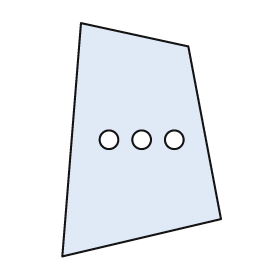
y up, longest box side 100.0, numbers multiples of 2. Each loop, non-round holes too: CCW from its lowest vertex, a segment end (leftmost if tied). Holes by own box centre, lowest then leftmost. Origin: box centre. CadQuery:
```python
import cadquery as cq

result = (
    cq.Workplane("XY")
    .moveTo(-34.0, -50.0)
    .lineTo(34.0, -34.0)
    .lineTo(20.0, 40.0)
    .lineTo(-26.0, 50.0)
    .close()
    .moveTo(-14.0, 0.0)
    .circle(4.0)
    .moveTo(0.0, 0.0)
    .circle(4.0)
    .moveTo(14.0, 0.0)
    .circle(4.0)
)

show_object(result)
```